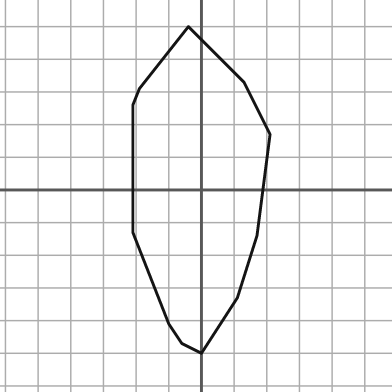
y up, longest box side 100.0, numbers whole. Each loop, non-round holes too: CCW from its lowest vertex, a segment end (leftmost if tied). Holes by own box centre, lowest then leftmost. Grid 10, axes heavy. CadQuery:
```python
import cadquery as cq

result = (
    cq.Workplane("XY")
    .moveTo(0.0, -50.0)
    .lineTo(11.0, -33.0)
    .lineTo(17.0, -14.0)
    .lineTo(21.0, 17.0)
    .lineTo(13.0, 33.0)
    .lineTo(-4.0, 50.0)
    .lineTo(-19.0, 31.0)
    .lineTo(-21.0, 26.0)
    .lineTo(-21.0, -13.0)
    .lineTo(-10.0, -41.0)
    .lineTo(-6.0, -47.0)
    .close()
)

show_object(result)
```